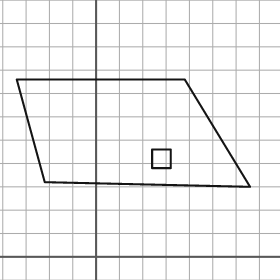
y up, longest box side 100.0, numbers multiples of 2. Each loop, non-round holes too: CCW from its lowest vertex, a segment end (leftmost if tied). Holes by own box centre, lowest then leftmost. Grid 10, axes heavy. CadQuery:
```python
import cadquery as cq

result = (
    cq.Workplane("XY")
    .moveTo(66.0, 30.0)
    .lineTo(38.0, 76.0)
    .lineTo(-34.0, 76.0)
    .lineTo(-22.0, 32.0)
    .close()
    .moveTo(24.0, 38.0)
    .lineTo(32.0, 38.0)
    .lineTo(32.0, 46.0)
    .lineTo(24.0, 46.0)
    .close()
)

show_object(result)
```